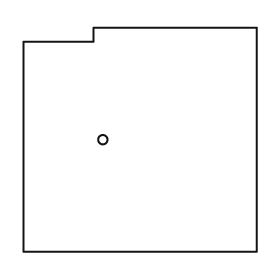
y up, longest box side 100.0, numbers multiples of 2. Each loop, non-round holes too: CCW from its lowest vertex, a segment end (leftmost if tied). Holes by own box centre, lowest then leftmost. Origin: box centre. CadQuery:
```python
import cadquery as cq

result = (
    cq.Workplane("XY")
    .moveTo(-50.0, -48.0)
    .lineTo(50.0, -48.0)
    .lineTo(50.0, 48.0)
    .lineTo(-20.0, 48.0)
    .lineTo(-20.0, 42.0)
    .lineTo(-50.0, 42.0)
    .close()
    .moveTo(-16.0, 0.0)
    .circle(2.0)
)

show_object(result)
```